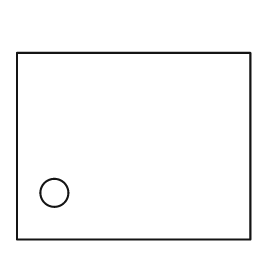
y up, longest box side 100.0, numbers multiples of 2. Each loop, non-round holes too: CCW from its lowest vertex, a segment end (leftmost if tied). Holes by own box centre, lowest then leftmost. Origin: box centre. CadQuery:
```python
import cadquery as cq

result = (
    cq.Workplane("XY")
    .moveTo(-50.0, -40.0)
    .lineTo(50.0, -40.0)
    .lineTo(50.0, 40.0)
    .lineTo(-50.0, 40.0)
    .close()
    .moveTo(-34.0, -20.0)
    .circle(6.0)
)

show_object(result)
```